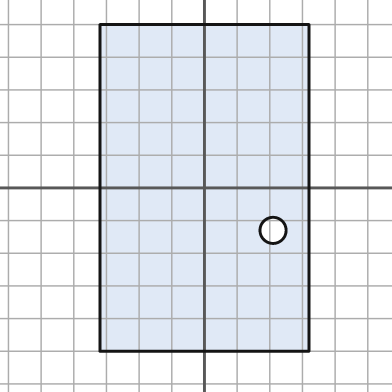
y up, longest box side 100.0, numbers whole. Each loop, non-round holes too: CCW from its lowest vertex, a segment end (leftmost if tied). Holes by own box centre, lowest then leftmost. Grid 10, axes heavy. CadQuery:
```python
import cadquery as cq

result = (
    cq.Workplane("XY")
    .moveTo(-32.0, -50.0)
    .lineTo(32.0, -50.0)
    .lineTo(32.0, 50.0)
    .lineTo(-32.0, 50.0)
    .close()
    .moveTo(21.0, -13.0)
    .circle(4.0)
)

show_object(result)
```